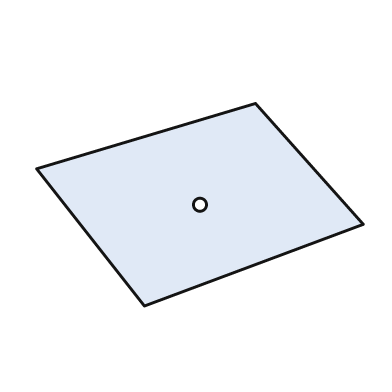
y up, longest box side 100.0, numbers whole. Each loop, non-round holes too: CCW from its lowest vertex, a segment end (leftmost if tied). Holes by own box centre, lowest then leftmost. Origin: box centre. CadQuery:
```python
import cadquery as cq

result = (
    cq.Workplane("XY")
    .moveTo(-17.0, -31.0)
    .lineTo(50.0, -6.0)
    .lineTo(17.0, 31.0)
    .lineTo(-50.0, 11.0)
    .close()
    .moveTo(0.0, 0.0)
    .circle(2.0)
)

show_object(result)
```